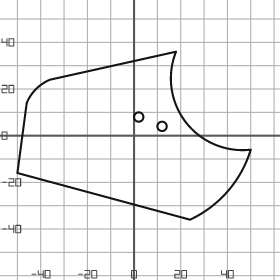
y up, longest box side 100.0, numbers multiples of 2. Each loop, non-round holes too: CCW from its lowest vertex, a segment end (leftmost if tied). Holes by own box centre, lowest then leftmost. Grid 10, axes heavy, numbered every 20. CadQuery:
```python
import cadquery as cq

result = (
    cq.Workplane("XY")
    .moveTo(24.0, -36.0)
    .threePointArc((40.0, -24.0), (50.0, -6.0))
    .threePointArc((22.0, 6.0), (18.0, 36.0))
    .lineTo(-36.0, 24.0)
    .threePointArc((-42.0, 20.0), (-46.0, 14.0))
    .lineTo(-50.0, -16.0)
    .close()
    .moveTo(12.0, 4.0)
    .circle(2.0)
    .moveTo(2.0, 8.0)
    .circle(2.0)
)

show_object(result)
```